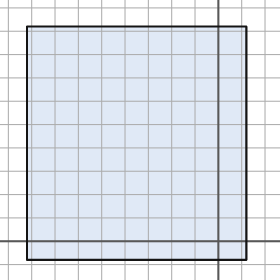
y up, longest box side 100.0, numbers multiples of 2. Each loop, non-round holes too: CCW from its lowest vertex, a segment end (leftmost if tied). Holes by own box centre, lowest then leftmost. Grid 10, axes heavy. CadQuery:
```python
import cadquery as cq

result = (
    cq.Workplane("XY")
    .moveTo(-82.0, -8.0)
    .lineTo(12.0, -8.0)
    .lineTo(12.0, 92.0)
    .lineTo(-82.0, 92.0)
    .close()
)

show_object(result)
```